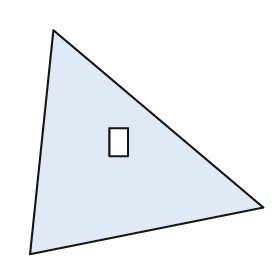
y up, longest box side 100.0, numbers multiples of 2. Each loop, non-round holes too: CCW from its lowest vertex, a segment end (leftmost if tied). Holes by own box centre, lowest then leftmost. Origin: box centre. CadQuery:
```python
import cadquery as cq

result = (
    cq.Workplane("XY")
    .moveTo(-50.0, -48.0)
    .lineTo(50.0, -28.0)
    .lineTo(-40.0, 48.0)
    .close()
    .moveTo(-16.0, -6.0)
    .lineTo(-8.0, -6.0)
    .lineTo(-8.0, 6.0)
    .lineTo(-16.0, 6.0)
    .close()
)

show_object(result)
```